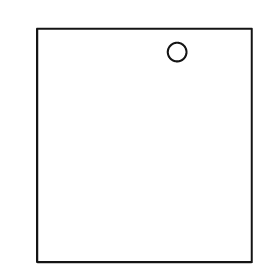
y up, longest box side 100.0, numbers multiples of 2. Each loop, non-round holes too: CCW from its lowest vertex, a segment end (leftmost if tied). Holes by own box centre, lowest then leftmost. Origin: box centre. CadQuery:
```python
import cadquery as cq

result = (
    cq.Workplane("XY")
    .moveTo(-46.0, -50.0)
    .lineTo(46.0, -50.0)
    .lineTo(46.0, 50.0)
    .lineTo(-46.0, 50.0)
    .close()
    .moveTo(14.0, 40.0)
    .circle(4.0)
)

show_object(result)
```